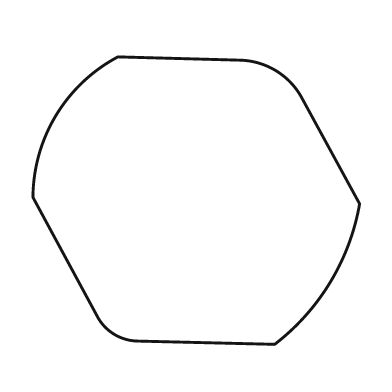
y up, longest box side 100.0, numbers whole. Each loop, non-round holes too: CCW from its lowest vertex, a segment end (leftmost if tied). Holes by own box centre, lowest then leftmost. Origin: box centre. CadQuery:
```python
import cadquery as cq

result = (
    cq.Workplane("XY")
    .moveTo(24.0, -44.0)
    .threePointArc((41.0, -25.0), (50.0, -1.0))
    .lineTo(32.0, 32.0)
    .threePointArc((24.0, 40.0), (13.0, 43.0))
    .lineTo(-24.0, 44.0)
    .threePointArc((-43.0, 26.0), (-50.0, 1.0))
    .lineTo(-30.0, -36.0)
    .threePointArc((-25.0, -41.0), (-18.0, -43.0))
    .close()
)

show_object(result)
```